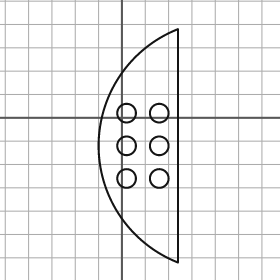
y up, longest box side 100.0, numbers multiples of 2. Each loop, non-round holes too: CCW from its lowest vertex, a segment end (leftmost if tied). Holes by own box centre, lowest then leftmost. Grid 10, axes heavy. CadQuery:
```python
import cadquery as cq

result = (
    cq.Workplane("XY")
    .moveTo(24.0, -62.0)
    .lineTo(24.0, 38.0)
    .threePointArc((-10.0, -12.0), (24.0, -62.0))
    .close()
    .moveTo(2.0, -26.0)
    .circle(4.0)
    .moveTo(16.0, -26.0)
    .circle(4.0)
    .moveTo(2.0, -12.0)
    .circle(4.0)
    .moveTo(16.0, -12.0)
    .circle(4.0)
    .moveTo(2.0, 2.0)
    .circle(4.0)
    .moveTo(16.0, 2.0)
    .circle(4.0)
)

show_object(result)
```